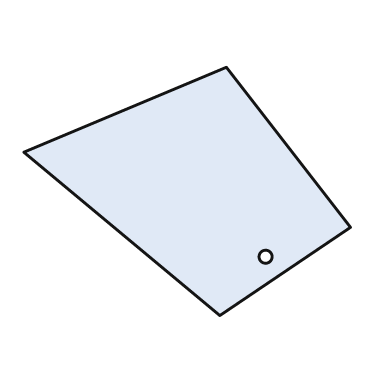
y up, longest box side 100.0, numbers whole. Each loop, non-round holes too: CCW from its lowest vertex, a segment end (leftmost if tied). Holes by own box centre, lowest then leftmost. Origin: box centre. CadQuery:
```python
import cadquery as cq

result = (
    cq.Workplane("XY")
    .moveTo(10.0, -38.0)
    .lineTo(50.0, -11.0)
    .lineTo(12.0, 38.0)
    .lineTo(-50.0, 12.0)
    .close()
    .moveTo(24.0, -20.0)
    .circle(2.0)
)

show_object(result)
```